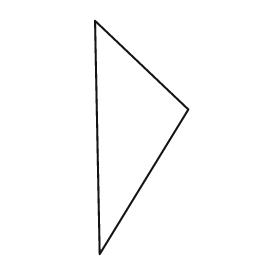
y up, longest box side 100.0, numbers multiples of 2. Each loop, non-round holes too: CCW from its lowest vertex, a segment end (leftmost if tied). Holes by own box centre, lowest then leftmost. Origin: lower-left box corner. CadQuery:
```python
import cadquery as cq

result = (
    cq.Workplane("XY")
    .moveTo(2.0, 0.0)
    .lineTo(40.0, 62.0)
    .lineTo(0.0, 100.0)
    .close()
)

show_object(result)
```